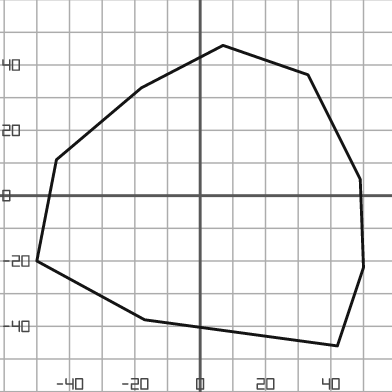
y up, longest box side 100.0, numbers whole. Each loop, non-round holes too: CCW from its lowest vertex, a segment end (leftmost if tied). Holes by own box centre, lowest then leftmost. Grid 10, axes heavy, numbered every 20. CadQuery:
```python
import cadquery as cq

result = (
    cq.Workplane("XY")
    .moveTo(42.0, -46.0)
    .lineTo(50.0, -22.0)
    .lineTo(49.0, 5.0)
    .lineTo(33.0, 37.0)
    .lineTo(7.0, 46.0)
    .lineTo(-18.0, 33.0)
    .lineTo(-44.0, 11.0)
    .lineTo(-50.0, -20.0)
    .lineTo(-17.0, -38.0)
    .close()
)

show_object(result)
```